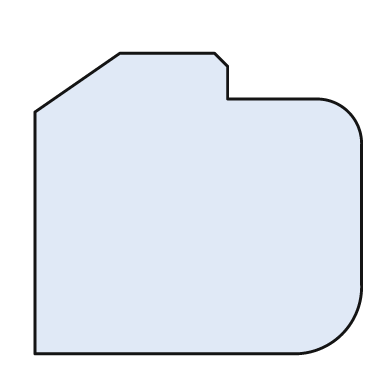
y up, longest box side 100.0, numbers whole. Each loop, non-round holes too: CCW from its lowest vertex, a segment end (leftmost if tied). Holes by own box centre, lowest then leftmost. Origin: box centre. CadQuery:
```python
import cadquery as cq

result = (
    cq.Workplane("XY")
    .moveTo(-50.0, -46.0)
    .lineTo(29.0, -46.0)
    .threePointArc((44.0, -40.0), (50.0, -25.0))
    .lineTo(50.0, 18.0)
    .threePointArc((46.0, 28.0), (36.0, 32.0))
    .lineTo(9.0, 32.0)
    .lineTo(9.0, 42.0)
    .lineTo(5.0, 46.0)
    .lineTo(-24.0, 46.0)
    .lineTo(-50.0, 28.0)
    .close()
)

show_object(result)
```